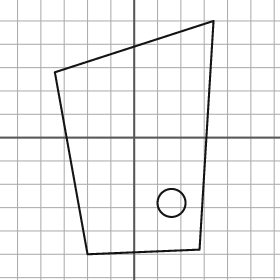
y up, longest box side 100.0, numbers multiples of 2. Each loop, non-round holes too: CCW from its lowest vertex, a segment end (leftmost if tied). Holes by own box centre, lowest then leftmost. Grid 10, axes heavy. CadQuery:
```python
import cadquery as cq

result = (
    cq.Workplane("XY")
    .moveTo(-20.0, -50.0)
    .lineTo(28.0, -48.0)
    .lineTo(34.0, 50.0)
    .lineTo(-34.0, 28.0)
    .close()
    .moveTo(16.0, -28.0)
    .circle(6.0)
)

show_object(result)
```